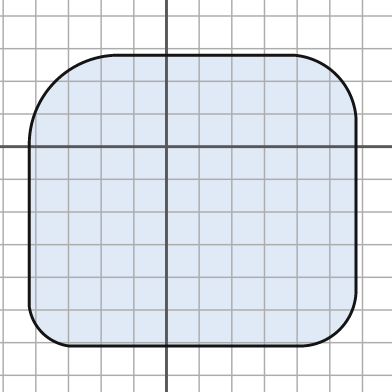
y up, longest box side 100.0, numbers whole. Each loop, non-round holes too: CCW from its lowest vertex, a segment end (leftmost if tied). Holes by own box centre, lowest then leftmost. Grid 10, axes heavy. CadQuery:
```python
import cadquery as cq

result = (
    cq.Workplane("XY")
    .moveTo(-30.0, -61.0)
    .lineTo(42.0, -61.0)
    .threePointArc((53.0, -56.0), (58.0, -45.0))
    .lineTo(58.0, 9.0)
    .threePointArc((52.0, 22.0), (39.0, 28.0))
    .lineTo(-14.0, 28.0)
    .threePointArc((-34.0, 20.0), (-42.0, 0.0))
    .lineTo(-42.0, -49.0)
    .threePointArc((-38.0, -57.0), (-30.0, -61.0))
    .close()
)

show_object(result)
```